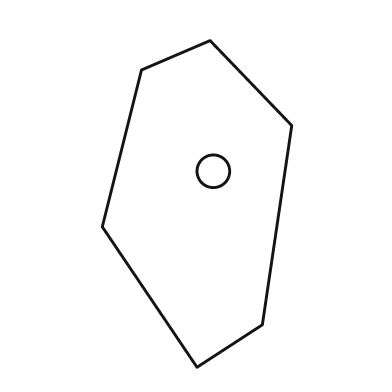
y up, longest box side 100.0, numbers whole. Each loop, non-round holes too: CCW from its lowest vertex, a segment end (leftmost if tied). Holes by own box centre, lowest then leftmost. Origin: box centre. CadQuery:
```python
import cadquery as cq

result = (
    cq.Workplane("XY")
    .moveTo(0.0, -50.0)
    .lineTo(20.0, -37.0)
    .lineTo(29.0, 24.0)
    .lineTo(4.0, 50.0)
    .lineTo(-17.0, 41.0)
    .lineTo(-29.0, -7.0)
    .close()
    .moveTo(5.0, 10.0)
    .circle(5.0)
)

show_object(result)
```